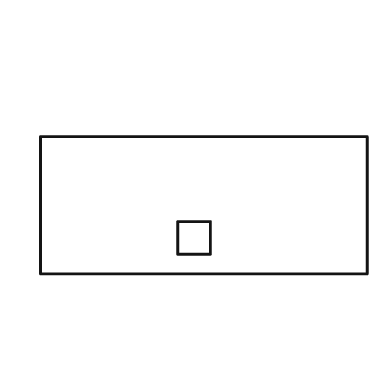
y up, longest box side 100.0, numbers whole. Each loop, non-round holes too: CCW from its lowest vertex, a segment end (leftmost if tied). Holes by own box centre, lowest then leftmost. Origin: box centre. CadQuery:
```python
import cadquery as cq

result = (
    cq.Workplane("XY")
    .moveTo(-50.0, -21.0)
    .lineTo(50.0, -21.0)
    .lineTo(50.0, 21.0)
    .lineTo(-50.0, 21.0)
    .close()
    .moveTo(-8.0, -15.0)
    .lineTo(2.0, -15.0)
    .lineTo(2.0, -5.0)
    .lineTo(-8.0, -5.0)
    .close()
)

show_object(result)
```